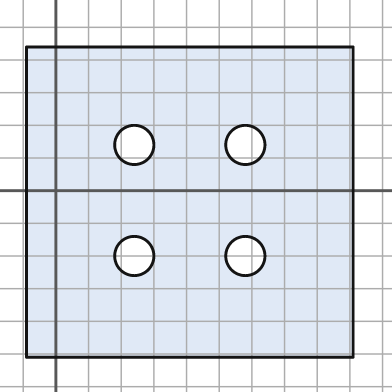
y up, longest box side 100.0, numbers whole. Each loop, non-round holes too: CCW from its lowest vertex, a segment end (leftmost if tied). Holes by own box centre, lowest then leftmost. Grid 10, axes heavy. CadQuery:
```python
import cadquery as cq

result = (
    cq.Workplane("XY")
    .moveTo(-9.0, -51.0)
    .lineTo(91.0, -51.0)
    .lineTo(91.0, 44.0)
    .lineTo(-9.0, 44.0)
    .close()
    .moveTo(24.0, -20.0)
    .circle(6.0)
    .moveTo(58.0, -20.0)
    .circle(6.0)
    .moveTo(24.0, 14.0)
    .circle(6.0)
    .moveTo(58.0, 14.0)
    .circle(6.0)
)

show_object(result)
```